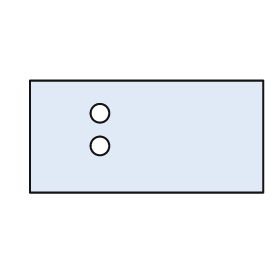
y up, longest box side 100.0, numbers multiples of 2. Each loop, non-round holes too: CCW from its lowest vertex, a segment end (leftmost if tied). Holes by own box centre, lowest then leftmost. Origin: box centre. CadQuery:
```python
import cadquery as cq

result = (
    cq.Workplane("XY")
    .moveTo(-50.0, -24.0)
    .lineTo(50.0, -24.0)
    .lineTo(50.0, 24.0)
    .lineTo(-50.0, 24.0)
    .close()
    .moveTo(-20.0, -4.0)
    .circle(4.0)
    .moveTo(-20.0, 10.0)
    .circle(4.0)
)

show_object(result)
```